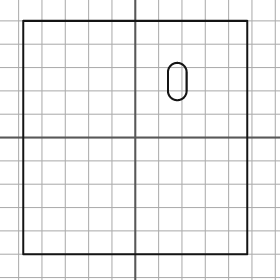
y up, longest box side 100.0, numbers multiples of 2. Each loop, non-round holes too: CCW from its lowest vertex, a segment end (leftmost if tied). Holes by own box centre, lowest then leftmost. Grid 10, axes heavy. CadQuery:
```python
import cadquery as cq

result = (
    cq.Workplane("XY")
    .moveTo(-48.0, -50.0)
    .lineTo(48.0, -50.0)
    .lineTo(48.0, 50.0)
    .lineTo(-48.0, 50.0)
    .close()
    .moveTo(14.0, 20.0)
    .threePointArc((18.0, 16.0), (22.0, 20.0))
    .lineTo(22.0, 28.0)
    .threePointArc((18.0, 32.0), (14.0, 28.0))
    .close()
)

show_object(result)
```